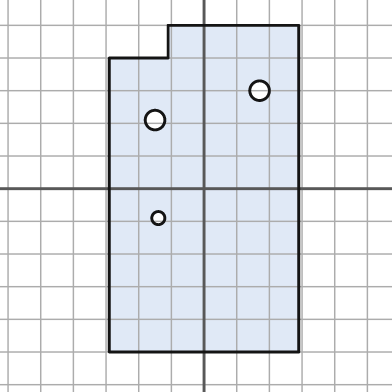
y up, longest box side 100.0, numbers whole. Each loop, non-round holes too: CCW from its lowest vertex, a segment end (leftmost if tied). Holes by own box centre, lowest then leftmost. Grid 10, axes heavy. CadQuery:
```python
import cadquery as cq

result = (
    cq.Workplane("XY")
    .moveTo(-29.0, -50.0)
    .lineTo(29.0, -50.0)
    .lineTo(29.0, 50.0)
    .lineTo(-11.0, 50.0)
    .lineTo(-11.0, 40.0)
    .lineTo(-29.0, 40.0)
    .close()
    .moveTo(-14.0, -9.0)
    .circle(2.0)
    .moveTo(-15.0, 21.0)
    .circle(3.0)
    .moveTo(17.0, 30.0)
    .circle(3.0)
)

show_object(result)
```